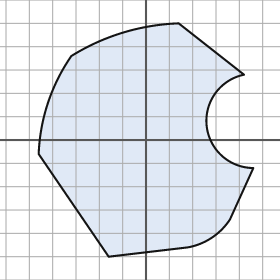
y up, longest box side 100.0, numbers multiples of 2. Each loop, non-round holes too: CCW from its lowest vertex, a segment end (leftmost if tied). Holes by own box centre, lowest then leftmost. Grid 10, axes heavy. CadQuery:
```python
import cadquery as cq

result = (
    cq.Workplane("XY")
    .moveTo(-16.0, -50.0)
    .lineTo(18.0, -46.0)
    .threePointArc((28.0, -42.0), (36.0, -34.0))
    .lineTo(46.0, -12.0)
    .threePointArc((26.0, 6.0), (42.0, 28.0))
    .lineTo(14.0, 50.0)
    .threePointArc((-10.0, 46.0), (-32.0, 36.0))
    .threePointArc((-42.0, 16.0), (-46.0, -6.0))
    .close()
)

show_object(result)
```